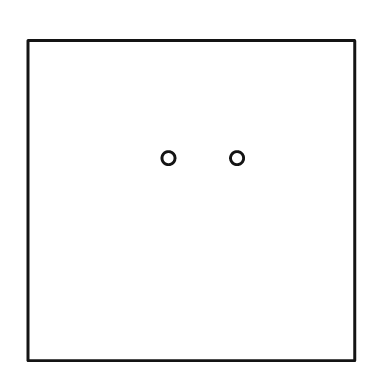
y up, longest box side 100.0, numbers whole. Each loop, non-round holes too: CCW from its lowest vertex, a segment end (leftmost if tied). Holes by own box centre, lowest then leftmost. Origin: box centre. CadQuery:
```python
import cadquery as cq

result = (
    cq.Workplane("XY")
    .moveTo(-50.0, -49.0)
    .lineTo(50.0, -49.0)
    .lineTo(50.0, 49.0)
    .lineTo(-50.0, 49.0)
    .close()
    .moveTo(-7.0, 13.0)
    .circle(2.0)
    .moveTo(14.0, 13.0)
    .circle(2.0)
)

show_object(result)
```